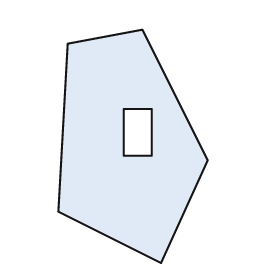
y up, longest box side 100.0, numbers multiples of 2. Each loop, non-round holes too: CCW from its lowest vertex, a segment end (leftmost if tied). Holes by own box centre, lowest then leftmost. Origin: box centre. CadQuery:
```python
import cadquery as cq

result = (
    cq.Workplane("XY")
    .moveTo(12.0, -50.0)
    .lineTo(32.0, -6.0)
    .lineTo(4.0, 50.0)
    .lineTo(-28.0, 44.0)
    .lineTo(-32.0, -28.0)
    .close()
    .moveTo(-4.0, -4.0)
    .lineTo(8.0, -4.0)
    .lineTo(8.0, 16.0)
    .lineTo(-4.0, 16.0)
    .close()
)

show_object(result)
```